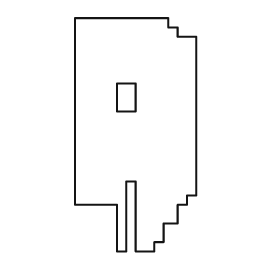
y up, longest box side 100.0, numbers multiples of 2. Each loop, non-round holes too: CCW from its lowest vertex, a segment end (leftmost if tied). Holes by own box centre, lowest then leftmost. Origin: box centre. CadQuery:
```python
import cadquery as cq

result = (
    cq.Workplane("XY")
    .moveTo(-8.0, -50.0)
    .lineTo(-4.0, -50.0)
    .lineTo(-4.0, -20.0)
    .lineTo(0.0, -20.0)
    .lineTo(0.0, -50.0)
    .lineTo(8.0, -50.0)
    .lineTo(8.0, -46.0)
    .lineTo(12.0, -46.0)
    .lineTo(12.0, -38.0)
    .lineTo(18.0, -38.0)
    .lineTo(18.0, -30.0)
    .lineTo(22.0, -30.0)
    .lineTo(22.0, -26.0)
    .lineTo(26.0, -26.0)
    .lineTo(26.0, 42.0)
    .lineTo(18.0, 42.0)
    .lineTo(18.0, 46.0)
    .lineTo(14.0, 46.0)
    .lineTo(14.0, 50.0)
    .lineTo(-26.0, 50.0)
    .lineTo(-26.0, -30.0)
    .lineTo(-8.0, -30.0)
    .close()
    .moveTo(-8.0, 10.0)
    .lineTo(0.0, 10.0)
    .lineTo(0.0, 22.0)
    .lineTo(-8.0, 22.0)
    .close()
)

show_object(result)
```